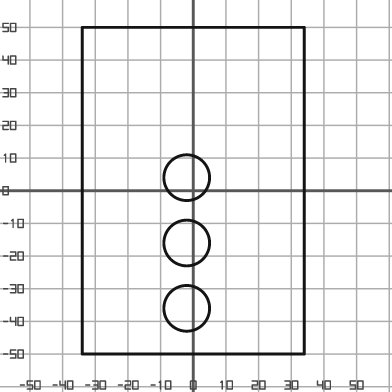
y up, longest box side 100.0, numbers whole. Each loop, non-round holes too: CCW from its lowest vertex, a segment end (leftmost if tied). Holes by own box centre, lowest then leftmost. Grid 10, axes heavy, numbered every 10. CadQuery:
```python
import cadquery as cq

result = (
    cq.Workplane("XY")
    .moveTo(-34.0, -50.0)
    .lineTo(34.0, -50.0)
    .lineTo(34.0, 50.0)
    .lineTo(-34.0, 50.0)
    .close()
    .moveTo(-2.0, -36.0)
    .circle(7.0)
    .moveTo(-2.0, -16.0)
    .circle(7.0)
    .moveTo(-2.0, 4.0)
    .circle(7.0)
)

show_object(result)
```